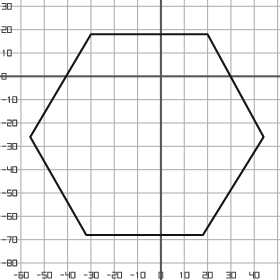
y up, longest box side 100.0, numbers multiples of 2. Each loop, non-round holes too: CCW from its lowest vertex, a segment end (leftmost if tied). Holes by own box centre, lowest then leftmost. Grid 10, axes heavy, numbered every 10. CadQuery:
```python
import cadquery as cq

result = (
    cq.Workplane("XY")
    .moveTo(-32.0, -68.0)
    .lineTo(18.0, -68.0)
    .lineTo(44.0, -26.0)
    .lineTo(20.0, 18.0)
    .lineTo(-30.0, 18.0)
    .lineTo(-56.0, -26.0)
    .close()
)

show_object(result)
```